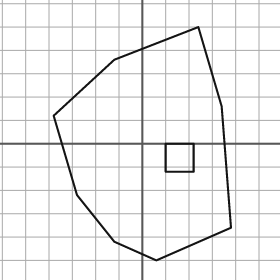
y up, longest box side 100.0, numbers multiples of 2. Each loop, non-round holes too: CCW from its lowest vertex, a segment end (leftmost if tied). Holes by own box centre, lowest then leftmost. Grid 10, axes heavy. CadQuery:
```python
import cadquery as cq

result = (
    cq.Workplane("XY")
    .moveTo(6.0, -50.0)
    .lineTo(38.0, -36.0)
    .lineTo(34.0, 16.0)
    .lineTo(24.0, 50.0)
    .lineTo(-12.0, 36.0)
    .lineTo(-38.0, 12.0)
    .lineTo(-28.0, -22.0)
    .lineTo(-12.0, -42.0)
    .close()
    .moveTo(10.0, -12.0)
    .lineTo(22.0, -12.0)
    .lineTo(22.0, 0.0)
    .lineTo(10.0, 0.0)
    .close()
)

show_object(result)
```